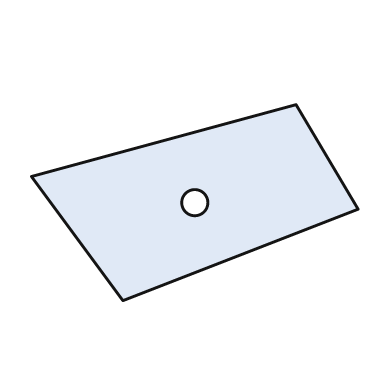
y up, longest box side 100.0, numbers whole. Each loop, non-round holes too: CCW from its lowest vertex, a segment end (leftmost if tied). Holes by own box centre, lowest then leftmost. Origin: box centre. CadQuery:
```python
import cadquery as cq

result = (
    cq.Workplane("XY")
    .moveTo(-22.0, -30.0)
    .lineTo(50.0, -2.0)
    .lineTo(31.0, 30.0)
    .lineTo(-50.0, 8.0)
    .close()
    .moveTo(0.0, 0.0)
    .circle(4.0)
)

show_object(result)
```